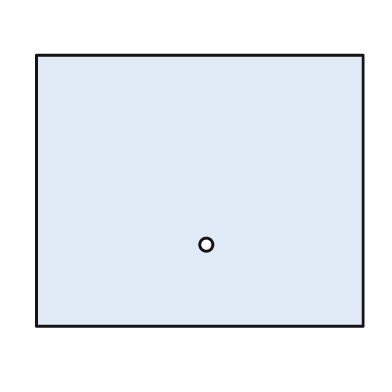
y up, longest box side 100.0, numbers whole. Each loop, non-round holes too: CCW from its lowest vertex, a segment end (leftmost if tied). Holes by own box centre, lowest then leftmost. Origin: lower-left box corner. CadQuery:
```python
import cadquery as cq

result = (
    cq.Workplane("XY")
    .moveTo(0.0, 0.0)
    .lineTo(100.0, 0.0)
    .lineTo(100.0, 83.0)
    .lineTo(0.0, 83.0)
    .close()
    .moveTo(52.0, 25.0)
    .circle(2.0)
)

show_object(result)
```